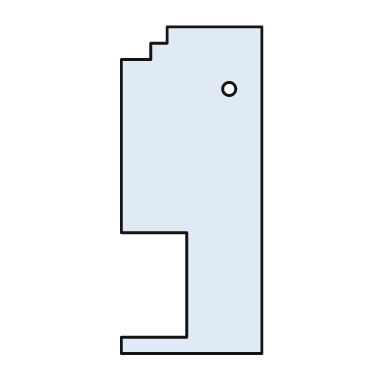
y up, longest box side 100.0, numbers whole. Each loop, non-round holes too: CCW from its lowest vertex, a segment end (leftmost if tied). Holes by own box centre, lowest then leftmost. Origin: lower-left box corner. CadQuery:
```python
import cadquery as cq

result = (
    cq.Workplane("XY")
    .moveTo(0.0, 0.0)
    .lineTo(43.0, 0.0)
    .lineTo(43.0, 100.0)
    .lineTo(14.0, 100.0)
    .lineTo(14.0, 95.0)
    .lineTo(9.0, 95.0)
    .lineTo(9.0, 90.0)
    .lineTo(0.0, 90.0)
    .lineTo(0.0, 37.0)
    .lineTo(20.0, 37.0)
    .lineTo(20.0, 5.0)
    .lineTo(0.0, 5.0)
    .close()
    .moveTo(33.0, 81.0)
    .circle(2.0)
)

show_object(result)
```